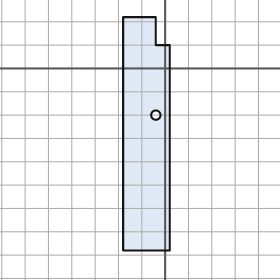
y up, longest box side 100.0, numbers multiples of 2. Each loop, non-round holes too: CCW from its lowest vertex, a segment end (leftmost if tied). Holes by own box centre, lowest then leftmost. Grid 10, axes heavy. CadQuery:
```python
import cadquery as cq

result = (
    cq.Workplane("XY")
    .moveTo(-18.0, -78.0)
    .lineTo(2.0, -78.0)
    .lineTo(2.0, 10.0)
    .lineTo(-4.0, 10.0)
    .lineTo(-4.0, 22.0)
    .lineTo(-18.0, 22.0)
    .close()
    .moveTo(-4.0, -20.0)
    .circle(2.0)
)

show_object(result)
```